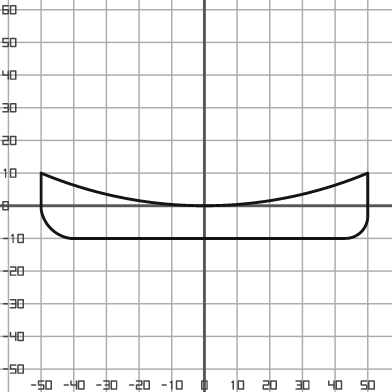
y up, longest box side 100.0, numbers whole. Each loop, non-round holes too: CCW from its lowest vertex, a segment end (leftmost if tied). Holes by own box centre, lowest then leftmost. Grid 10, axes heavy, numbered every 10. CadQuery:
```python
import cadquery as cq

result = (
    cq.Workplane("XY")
    .moveTo(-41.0, -10.0)
    .lineTo(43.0, -10.0)
    .threePointArc((48.0, -8.0), (50.0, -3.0))
    .lineTo(50.0, 10.0)
    .threePointArc((0.0, 0.0), (-50.0, 10.0))
    .lineTo(-50.0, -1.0)
    .threePointArc((-47.0, -7.0), (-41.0, -10.0))
    .close()
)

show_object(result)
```